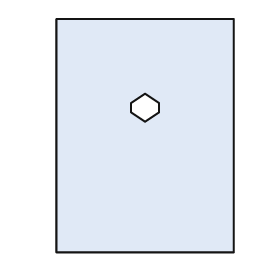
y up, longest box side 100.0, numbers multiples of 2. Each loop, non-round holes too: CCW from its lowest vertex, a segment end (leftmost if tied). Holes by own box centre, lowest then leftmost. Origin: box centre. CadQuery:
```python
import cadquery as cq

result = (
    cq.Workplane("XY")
    .moveTo(-38.0, -50.0)
    .lineTo(38.0, -50.0)
    .lineTo(38.0, 50.0)
    .lineTo(-38.0, 50.0)
    .close()
    .moveTo(0.0, 6.0)
    .lineTo(6.0, 10.0)
    .lineTo(6.0, 14.0)
    .lineTo(0.0, 18.0)
    .lineTo(-6.0, 14.0)
    .lineTo(-6.0, 10.0)
    .close()
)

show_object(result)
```